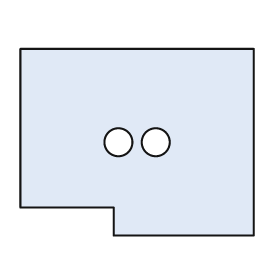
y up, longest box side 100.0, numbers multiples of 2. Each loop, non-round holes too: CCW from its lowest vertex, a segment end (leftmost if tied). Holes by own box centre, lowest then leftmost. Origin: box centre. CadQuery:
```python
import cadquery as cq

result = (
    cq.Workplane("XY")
    .moveTo(-10.0, -40.0)
    .lineTo(50.0, -40.0)
    .lineTo(50.0, 40.0)
    .lineTo(-50.0, 40.0)
    .lineTo(-50.0, -28.0)
    .lineTo(-10.0, -28.0)
    .close()
    .moveTo(-8.0, 0.0)
    .circle(6.0)
    .moveTo(8.0, 0.0)
    .circle(6.0)
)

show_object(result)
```